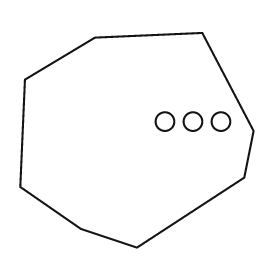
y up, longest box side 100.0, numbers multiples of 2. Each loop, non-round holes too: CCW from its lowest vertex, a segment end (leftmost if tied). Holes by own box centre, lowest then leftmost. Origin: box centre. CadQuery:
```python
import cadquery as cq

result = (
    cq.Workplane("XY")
    .moveTo(0.0, -46.0)
    .lineTo(46.0, -16.0)
    .lineTo(50.0, 4.0)
    .lineTo(28.0, 46.0)
    .lineTo(-18.0, 44.0)
    .lineTo(-48.0, 26.0)
    .lineTo(-50.0, -20.0)
    .lineTo(-24.0, -38.0)
    .close()
    .moveTo(12.0, 8.0)
    .circle(4.0)
    .moveTo(24.0, 8.0)
    .circle(4.0)
    .moveTo(36.0, 8.0)
    .circle(4.0)
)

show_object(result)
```